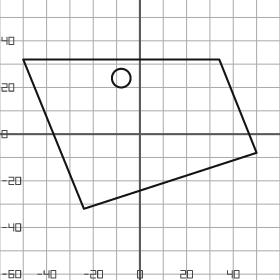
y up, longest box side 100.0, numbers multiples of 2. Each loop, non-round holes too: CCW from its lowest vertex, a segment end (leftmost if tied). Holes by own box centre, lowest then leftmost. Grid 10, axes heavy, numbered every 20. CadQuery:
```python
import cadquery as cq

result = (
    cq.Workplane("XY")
    .moveTo(-24.0, -32.0)
    .lineTo(50.0, -8.0)
    .lineTo(34.0, 32.0)
    .lineTo(-50.0, 32.0)
    .close()
    .moveTo(-8.0, 24.0)
    .circle(4.0)
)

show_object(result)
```